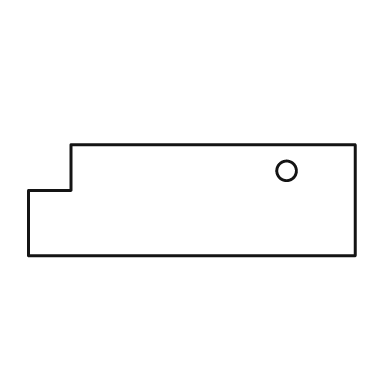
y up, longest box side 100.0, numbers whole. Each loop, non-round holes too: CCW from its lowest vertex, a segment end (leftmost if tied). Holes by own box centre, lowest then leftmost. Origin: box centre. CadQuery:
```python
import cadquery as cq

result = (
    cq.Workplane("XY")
    .moveTo(-50.0, -17.0)
    .lineTo(50.0, -17.0)
    .lineTo(50.0, 17.0)
    .lineTo(-37.0, 17.0)
    .lineTo(-37.0, 3.0)
    .lineTo(-50.0, 3.0)
    .close()
    .moveTo(29.0, 9.0)
    .circle(3.0)
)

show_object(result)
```